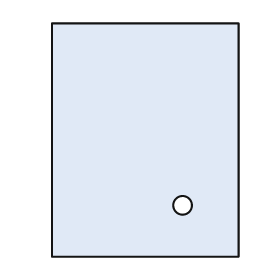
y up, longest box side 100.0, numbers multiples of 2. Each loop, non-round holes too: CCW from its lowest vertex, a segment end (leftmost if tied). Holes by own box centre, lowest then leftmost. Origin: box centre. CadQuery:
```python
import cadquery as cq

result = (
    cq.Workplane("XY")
    .moveTo(-40.0, -50.0)
    .lineTo(40.0, -50.0)
    .lineTo(40.0, 50.0)
    .lineTo(-40.0, 50.0)
    .close()
    .moveTo(16.0, -28.0)
    .circle(4.0)
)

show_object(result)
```